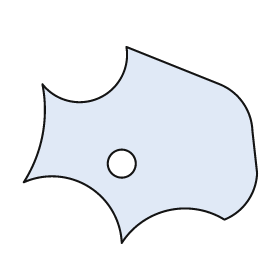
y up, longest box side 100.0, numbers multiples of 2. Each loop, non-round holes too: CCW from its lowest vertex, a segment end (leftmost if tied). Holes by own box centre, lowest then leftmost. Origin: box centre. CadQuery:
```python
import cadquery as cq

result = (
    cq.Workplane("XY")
    .moveTo(-8.0, -42.0)
    .threePointArc((12.0, -28.0), (36.0, -32.0))
    .threePointArc((46.0, -24.0), (50.0, -12.0))
    .lineTo(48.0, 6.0)
    .threePointArc((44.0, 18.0), (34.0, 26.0))
    .lineTo(-6.0, 42.0)
    .threePointArc((-18.0, 20.0), (-42.0, 26.0))
    .threePointArc((-42.0, 4.0), (-50.0, -16.0))
    .threePointArc((-22.0, -18.0), (-8.0, -42.0))
    .close()
    .moveTo(-8.0, -8.0)
    .circle(6.0)
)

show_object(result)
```